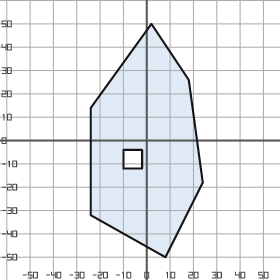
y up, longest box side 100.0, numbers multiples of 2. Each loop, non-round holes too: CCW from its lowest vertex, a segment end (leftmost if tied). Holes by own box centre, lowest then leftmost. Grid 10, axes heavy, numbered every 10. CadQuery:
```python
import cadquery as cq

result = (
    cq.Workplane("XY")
    .moveTo(8.0, -50.0)
    .lineTo(24.0, -18.0)
    .lineTo(18.0, 26.0)
    .lineTo(2.0, 50.0)
    .lineTo(-24.0, 14.0)
    .lineTo(-24.0, -32.0)
    .close()
    .moveTo(-10.0, -12.0)
    .lineTo(-2.0, -12.0)
    .lineTo(-2.0, -4.0)
    .lineTo(-10.0, -4.0)
    .close()
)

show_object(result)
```